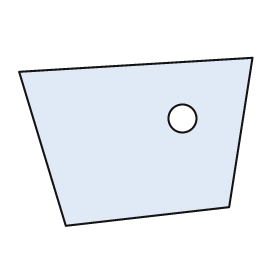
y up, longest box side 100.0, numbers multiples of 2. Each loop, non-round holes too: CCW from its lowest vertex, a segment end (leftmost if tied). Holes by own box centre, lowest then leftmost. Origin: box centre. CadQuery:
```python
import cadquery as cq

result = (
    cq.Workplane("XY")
    .moveTo(-30.0, -36.0)
    .lineTo(40.0, -28.0)
    .lineTo(50.0, 36.0)
    .lineTo(-50.0, 30.0)
    .close()
    .moveTo(20.0, 10.0)
    .circle(6.0)
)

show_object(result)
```